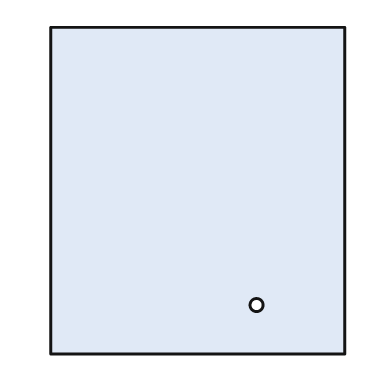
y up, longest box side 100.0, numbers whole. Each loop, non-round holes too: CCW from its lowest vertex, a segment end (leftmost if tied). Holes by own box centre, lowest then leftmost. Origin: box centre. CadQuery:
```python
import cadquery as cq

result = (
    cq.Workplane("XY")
    .moveTo(-45.0, -50.0)
    .lineTo(45.0, -50.0)
    .lineTo(45.0, 50.0)
    .lineTo(-45.0, 50.0)
    .close()
    .moveTo(18.0, -35.0)
    .circle(2.0)
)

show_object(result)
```